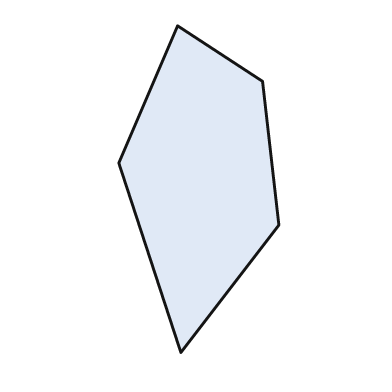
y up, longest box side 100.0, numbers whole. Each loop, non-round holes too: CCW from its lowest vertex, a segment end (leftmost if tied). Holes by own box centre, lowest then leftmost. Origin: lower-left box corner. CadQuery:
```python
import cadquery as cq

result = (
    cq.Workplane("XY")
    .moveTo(19.0, 0.0)
    .lineTo(49.0, 39.0)
    .lineTo(44.0, 83.0)
    .lineTo(18.0, 100.0)
    .lineTo(0.0, 58.0)
    .close()
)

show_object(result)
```